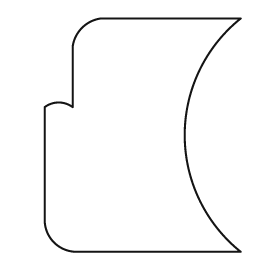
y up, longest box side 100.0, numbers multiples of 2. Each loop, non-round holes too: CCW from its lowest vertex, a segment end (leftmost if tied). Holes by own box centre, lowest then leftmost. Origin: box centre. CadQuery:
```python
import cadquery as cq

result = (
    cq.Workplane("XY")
    .moveTo(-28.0, -50.0)
    .lineTo(42.0, -50.0)
    .threePointArc((18.0, 0.0), (42.0, 50.0))
    .lineTo(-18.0, 50.0)
    .threePointArc((-26.0, 46.0), (-30.0, 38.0))
    .lineTo(-30.0, 12.0)
    .threePointArc((-36.0, 14.0), (-42.0, 12.0))
    .lineTo(-42.0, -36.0)
    .threePointArc((-38.0, -46.0), (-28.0, -50.0))
    .close()
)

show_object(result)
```